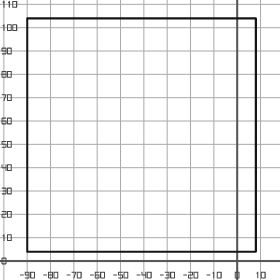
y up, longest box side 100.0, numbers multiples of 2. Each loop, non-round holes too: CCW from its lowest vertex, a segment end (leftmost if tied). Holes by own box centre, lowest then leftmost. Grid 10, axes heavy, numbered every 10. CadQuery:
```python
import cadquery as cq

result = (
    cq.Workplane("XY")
    .moveTo(-90.0, 4.0)
    .lineTo(8.0, 4.0)
    .lineTo(8.0, 104.0)
    .lineTo(-90.0, 104.0)
    .close()
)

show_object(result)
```